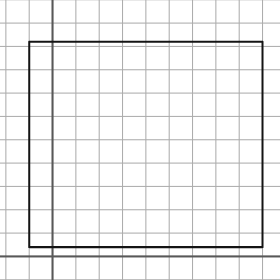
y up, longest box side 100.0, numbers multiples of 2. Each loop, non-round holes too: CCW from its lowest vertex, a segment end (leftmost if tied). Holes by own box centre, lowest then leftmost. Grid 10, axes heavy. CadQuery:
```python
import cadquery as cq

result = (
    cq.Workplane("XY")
    .moveTo(-10.0, 4.0)
    .lineTo(90.0, 4.0)
    .lineTo(90.0, 92.0)
    .lineTo(-10.0, 92.0)
    .close()
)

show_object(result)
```